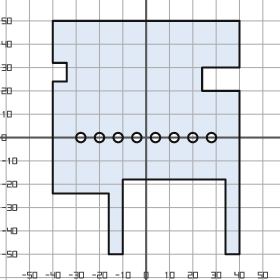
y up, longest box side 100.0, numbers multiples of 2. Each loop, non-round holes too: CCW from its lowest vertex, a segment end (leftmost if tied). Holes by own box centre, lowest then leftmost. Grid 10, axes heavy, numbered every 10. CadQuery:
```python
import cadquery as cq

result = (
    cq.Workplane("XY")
    .moveTo(-16.0, -50.0)
    .lineTo(-10.0, -50.0)
    .lineTo(-10.0, -18.0)
    .lineTo(34.0, -18.0)
    .lineTo(34.0, -50.0)
    .lineTo(40.0, -50.0)
    .lineTo(40.0, 20.0)
    .lineTo(24.0, 20.0)
    .lineTo(24.0, 30.0)
    .lineTo(40.0, 30.0)
    .lineTo(40.0, 50.0)
    .lineTo(-40.0, 50.0)
    .lineTo(-40.0, 32.0)
    .lineTo(-34.0, 32.0)
    .lineTo(-34.0, 24.0)
    .lineTo(-40.0, 24.0)
    .lineTo(-40.0, -24.0)
    .lineTo(-16.0, -24.0)
    .close()
    .moveTo(-28.0, 0.0)
    .circle(2.0)
    .moveTo(-20.0, 0.0)
    .circle(2.0)
    .moveTo(-12.0, 0.0)
    .circle(2.0)
    .moveTo(-4.0, 0.0)
    .circle(2.0)
    .moveTo(4.0, 0.0)
    .circle(2.0)
    .moveTo(12.0, 0.0)
    .circle(2.0)
    .moveTo(20.0, 0.0)
    .circle(2.0)
    .moveTo(28.0, 0.0)
    .circle(2.0)
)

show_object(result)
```